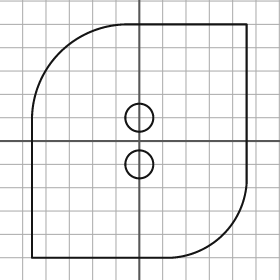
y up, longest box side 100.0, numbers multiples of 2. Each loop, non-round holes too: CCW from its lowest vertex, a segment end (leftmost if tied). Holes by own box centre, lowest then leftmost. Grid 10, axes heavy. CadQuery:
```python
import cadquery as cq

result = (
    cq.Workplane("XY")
    .moveTo(-46.0, -50.0)
    .lineTo(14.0, -50.0)
    .threePointArc((36.0, -40.0), (46.0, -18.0))
    .lineTo(46.0, 50.0)
    .lineTo(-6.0, 50.0)
    .threePointArc((-34.0, 38.0), (-46.0, 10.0))
    .close()
    .moveTo(0.0, -10.0)
    .circle(6.0)
    .moveTo(0.0, 10.0)
    .circle(6.0)
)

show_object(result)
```